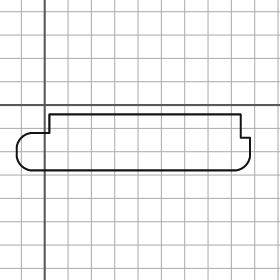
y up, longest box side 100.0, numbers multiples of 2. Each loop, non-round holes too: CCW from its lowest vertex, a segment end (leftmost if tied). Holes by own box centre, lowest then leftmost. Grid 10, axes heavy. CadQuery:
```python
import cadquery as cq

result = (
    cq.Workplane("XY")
    .moveTo(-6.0, -28.0)
    .lineTo(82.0, -28.0)
    .threePointArc((86.0, -26.0), (88.0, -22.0))
    .lineTo(88.0, -14.0)
    .lineTo(84.0, -14.0)
    .lineTo(84.0, -4.0)
    .lineTo(2.0, -4.0)
    .lineTo(2.0, -12.0)
    .lineTo(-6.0, -12.0)
    .threePointArc((-10.0, -14.0), (-12.0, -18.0))
    .lineTo(-12.0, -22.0)
    .threePointArc((-10.0, -26.0), (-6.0, -28.0))
    .close()
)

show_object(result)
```